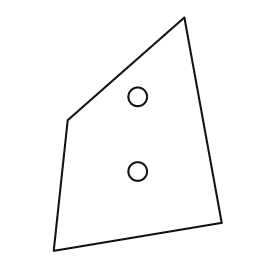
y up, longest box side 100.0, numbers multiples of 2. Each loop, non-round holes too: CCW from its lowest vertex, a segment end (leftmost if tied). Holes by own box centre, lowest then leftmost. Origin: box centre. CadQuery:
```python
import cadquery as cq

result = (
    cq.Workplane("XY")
    .moveTo(-36.0, -50.0)
    .lineTo(36.0, -38.0)
    .lineTo(20.0, 50.0)
    .lineTo(-30.0, 6.0)
    .close()
    .moveTo(0.0, -16.0)
    .circle(4.0)
    .moveTo(0.0, 16.0)
    .circle(4.0)
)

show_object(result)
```